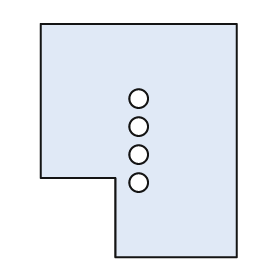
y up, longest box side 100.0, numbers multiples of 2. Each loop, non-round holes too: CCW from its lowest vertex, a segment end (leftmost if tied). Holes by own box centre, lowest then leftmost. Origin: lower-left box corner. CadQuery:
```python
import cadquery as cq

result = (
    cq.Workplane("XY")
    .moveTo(32.0, 0.0)
    .lineTo(84.0, 0.0)
    .lineTo(84.0, 100.0)
    .lineTo(0.0, 100.0)
    .lineTo(0.0, 34.0)
    .lineTo(32.0, 34.0)
    .close()
    .moveTo(42.0, 32.0)
    .circle(4.0)
    .moveTo(42.0, 44.0)
    .circle(4.0)
    .moveTo(42.0, 56.0)
    .circle(4.0)
    .moveTo(42.0, 68.0)
    .circle(4.0)
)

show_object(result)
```